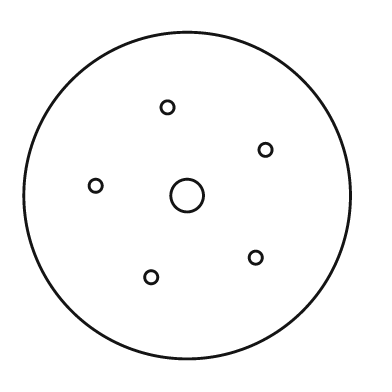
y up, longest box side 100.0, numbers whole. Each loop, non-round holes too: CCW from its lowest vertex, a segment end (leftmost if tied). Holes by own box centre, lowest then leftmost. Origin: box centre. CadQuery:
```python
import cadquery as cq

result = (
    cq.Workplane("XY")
    .moveTo(0.0, 0.0)
    .circle(50.0)
    .moveTo(-11.0, -25.0)
    .circle(2.0)
    .moveTo(21.0, -19.0)
    .circle(2.0)
    .moveTo(0.0, 0.0)
    .circle(5.0)
    .moveTo(-28.0, 3.0)
    .circle(2.0)
    .moveTo(24.0, 14.0)
    .circle(2.0)
    .moveTo(-6.0, 27.0)
    .circle(2.0)
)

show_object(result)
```